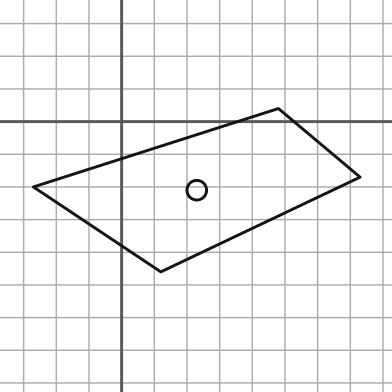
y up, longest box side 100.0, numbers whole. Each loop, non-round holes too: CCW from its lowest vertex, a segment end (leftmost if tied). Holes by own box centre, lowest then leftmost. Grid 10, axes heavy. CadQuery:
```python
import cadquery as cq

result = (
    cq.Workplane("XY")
    .moveTo(12.0, -46.0)
    .lineTo(73.0, -17.0)
    .lineTo(48.0, 4.0)
    .lineTo(-27.0, -20.0)
    .close()
    .moveTo(23.0, -21.0)
    .circle(3.0)
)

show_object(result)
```